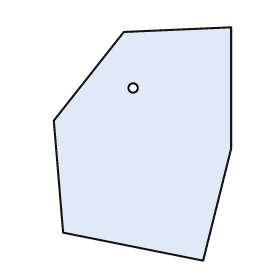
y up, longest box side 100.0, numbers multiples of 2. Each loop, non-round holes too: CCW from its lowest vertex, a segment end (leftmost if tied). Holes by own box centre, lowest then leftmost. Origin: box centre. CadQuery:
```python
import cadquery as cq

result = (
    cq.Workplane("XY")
    .moveTo(26.0, -50.0)
    .lineTo(38.0, -2.0)
    .lineTo(38.0, 50.0)
    .lineTo(-8.0, 48.0)
    .lineTo(-38.0, 10.0)
    .lineTo(-34.0, -38.0)
    .close()
    .moveTo(-4.0, 24.0)
    .circle(2.0)
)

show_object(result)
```